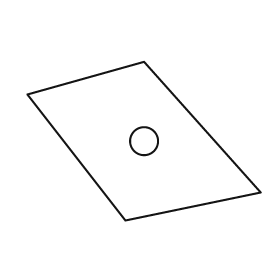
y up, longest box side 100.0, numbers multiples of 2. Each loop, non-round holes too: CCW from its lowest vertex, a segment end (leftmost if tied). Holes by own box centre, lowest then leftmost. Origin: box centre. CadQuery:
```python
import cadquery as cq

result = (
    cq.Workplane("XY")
    .moveTo(-8.0, -34.0)
    .lineTo(50.0, -22.0)
    .lineTo(0.0, 34.0)
    .lineTo(-50.0, 20.0)
    .close()
    .moveTo(0.0, 0.0)
    .circle(6.0)
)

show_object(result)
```